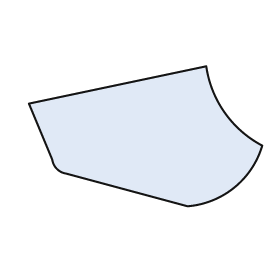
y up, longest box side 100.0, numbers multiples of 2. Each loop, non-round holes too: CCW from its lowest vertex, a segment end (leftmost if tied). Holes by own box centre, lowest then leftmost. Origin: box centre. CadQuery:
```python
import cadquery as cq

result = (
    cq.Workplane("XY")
    .moveTo(18.0, -30.0)
    .threePointArc((38.0, -22.0), (50.0, -4.0))
    .threePointArc((34.0, 10.0), (26.0, 30.0))
    .lineTo(-50.0, 14.0)
    .lineTo(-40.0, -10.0)
    .threePointArc((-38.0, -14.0), (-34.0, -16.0))
    .close()
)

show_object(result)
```